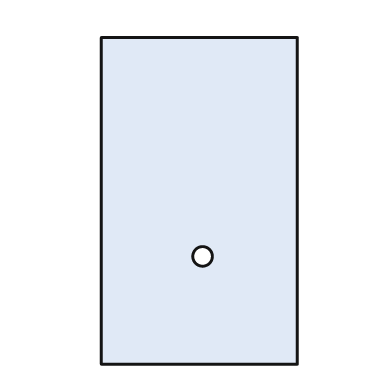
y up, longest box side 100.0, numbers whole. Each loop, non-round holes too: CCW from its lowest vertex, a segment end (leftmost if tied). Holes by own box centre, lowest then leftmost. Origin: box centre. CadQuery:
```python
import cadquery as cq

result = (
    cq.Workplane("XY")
    .moveTo(-30.0, -50.0)
    .lineTo(30.0, -50.0)
    .lineTo(30.0, 50.0)
    .lineTo(-30.0, 50.0)
    .close()
    .moveTo(1.0, -17.0)
    .circle(3.0)
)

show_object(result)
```